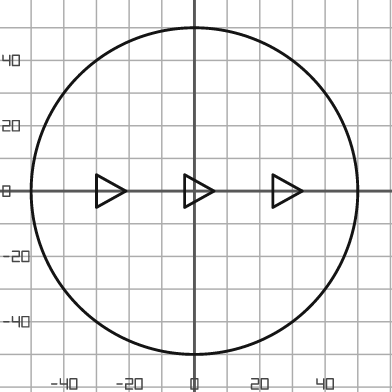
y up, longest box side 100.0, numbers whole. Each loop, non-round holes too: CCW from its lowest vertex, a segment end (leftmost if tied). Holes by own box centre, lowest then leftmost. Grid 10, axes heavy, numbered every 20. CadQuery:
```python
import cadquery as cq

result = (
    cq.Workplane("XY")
    .moveTo(0.0, 0.0)
    .circle(50.0)
    .moveTo(-30.0, -5.0)
    .lineTo(-21.0, 0.0)
    .lineTo(-30.0, 5.0)
    .close()
    .moveTo(-3.0, -5.0)
    .lineTo(6.0, 0.0)
    .lineTo(-3.0, 5.0)
    .close()
    .moveTo(24.0, -5.0)
    .lineTo(33.0, 0.0)
    .lineTo(24.0, 5.0)
    .close()
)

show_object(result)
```